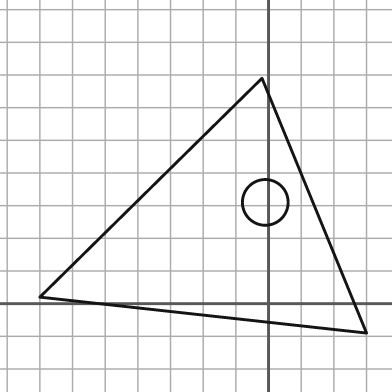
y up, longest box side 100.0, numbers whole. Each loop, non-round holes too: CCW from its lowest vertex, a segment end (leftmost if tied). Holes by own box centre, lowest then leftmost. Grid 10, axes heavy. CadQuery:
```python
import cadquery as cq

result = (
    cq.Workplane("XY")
    .moveTo(30.0, -9.0)
    .lineTo(-2.0, 69.0)
    .lineTo(-70.0, 2.0)
    .close()
    .moveTo(-1.0, 31.0)
    .circle(7.0)
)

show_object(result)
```